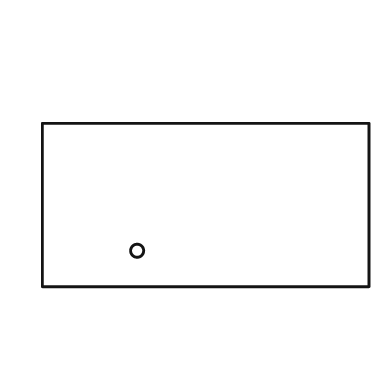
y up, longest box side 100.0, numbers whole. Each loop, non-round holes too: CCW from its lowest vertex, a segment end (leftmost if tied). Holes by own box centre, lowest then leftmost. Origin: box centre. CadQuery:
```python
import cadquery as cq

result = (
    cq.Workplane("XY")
    .moveTo(-50.0, -25.0)
    .lineTo(50.0, -25.0)
    .lineTo(50.0, 25.0)
    .lineTo(-50.0, 25.0)
    .close()
    .moveTo(-21.0, -14.0)
    .circle(2.0)
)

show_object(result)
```